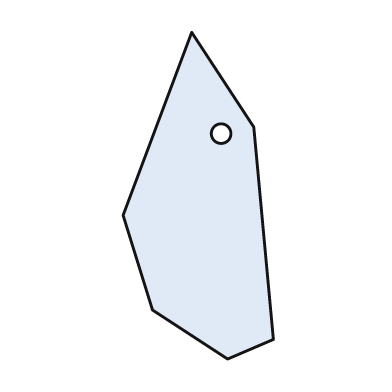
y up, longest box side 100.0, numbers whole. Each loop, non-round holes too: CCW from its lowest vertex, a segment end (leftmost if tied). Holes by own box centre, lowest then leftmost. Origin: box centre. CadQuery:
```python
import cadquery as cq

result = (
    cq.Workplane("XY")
    .moveTo(9.0, -50.0)
    .lineTo(23.0, -44.0)
    .lineTo(17.0, 21.0)
    .lineTo(-2.0, 50.0)
    .lineTo(-23.0, -6.0)
    .lineTo(-14.0, -35.0)
    .close()
    .moveTo(7.0, 19.0)
    .circle(3.0)
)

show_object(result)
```